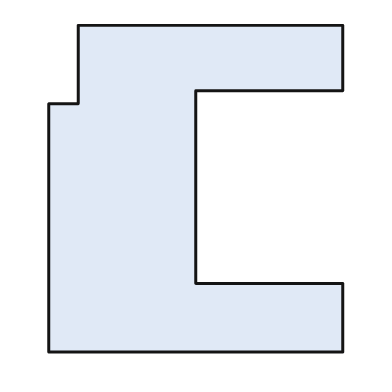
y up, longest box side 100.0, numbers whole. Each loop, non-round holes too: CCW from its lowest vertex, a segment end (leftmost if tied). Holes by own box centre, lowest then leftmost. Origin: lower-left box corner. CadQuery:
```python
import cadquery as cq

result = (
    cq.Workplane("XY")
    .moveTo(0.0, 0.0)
    .lineTo(90.0, 0.0)
    .lineTo(90.0, 21.0)
    .lineTo(45.0, 21.0)
    .lineTo(45.0, 80.0)
    .lineTo(90.0, 80.0)
    .lineTo(90.0, 100.0)
    .lineTo(9.0, 100.0)
    .lineTo(9.0, 76.0)
    .lineTo(0.0, 76.0)
    .close()
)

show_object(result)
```